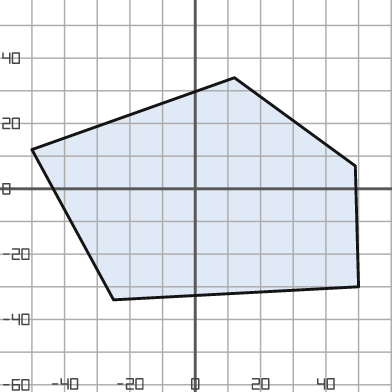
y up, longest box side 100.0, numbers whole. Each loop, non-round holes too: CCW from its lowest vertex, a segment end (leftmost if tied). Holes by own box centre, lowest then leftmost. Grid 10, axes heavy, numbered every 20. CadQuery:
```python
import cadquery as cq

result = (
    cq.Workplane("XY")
    .moveTo(-25.0, -34.0)
    .lineTo(50.0, -30.0)
    .lineTo(49.0, 7.0)
    .lineTo(12.0, 34.0)
    .lineTo(-50.0, 12.0)
    .close()
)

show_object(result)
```